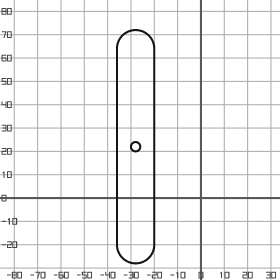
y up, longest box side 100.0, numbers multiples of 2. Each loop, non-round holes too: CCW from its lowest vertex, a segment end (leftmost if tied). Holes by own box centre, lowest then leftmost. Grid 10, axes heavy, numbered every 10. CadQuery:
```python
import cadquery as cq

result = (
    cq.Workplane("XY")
    .moveTo(-36.0, -20.0)
    .threePointArc((-28.0, -28.0), (-20.0, -20.0))
    .lineTo(-20.0, 64.0)
    .threePointArc((-28.0, 72.0), (-36.0, 64.0))
    .close()
    .moveTo(-28.0, 22.0)
    .circle(2.0)
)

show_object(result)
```